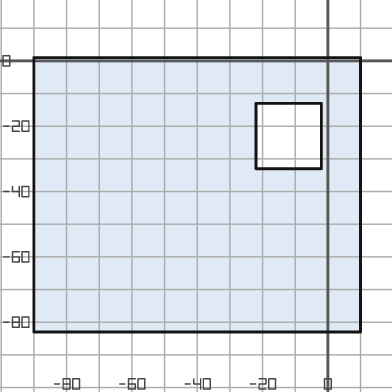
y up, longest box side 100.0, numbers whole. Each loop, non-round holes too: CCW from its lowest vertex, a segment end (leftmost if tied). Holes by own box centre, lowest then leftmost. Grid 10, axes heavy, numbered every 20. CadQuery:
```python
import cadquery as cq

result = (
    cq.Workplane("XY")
    .moveTo(-90.0, -83.0)
    .lineTo(10.0, -83.0)
    .lineTo(10.0, 1.0)
    .lineTo(-90.0, 1.0)
    .close()
    .moveTo(-22.0, -33.0)
    .lineTo(-2.0, -33.0)
    .lineTo(-2.0, -13.0)
    .lineTo(-22.0, -13.0)
    .close()
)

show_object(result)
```